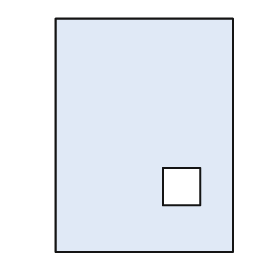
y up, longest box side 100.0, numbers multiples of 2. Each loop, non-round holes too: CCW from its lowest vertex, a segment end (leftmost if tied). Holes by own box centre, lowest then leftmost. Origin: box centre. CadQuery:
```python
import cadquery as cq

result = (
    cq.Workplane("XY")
    .moveTo(-38.0, -50.0)
    .lineTo(38.0, -50.0)
    .lineTo(38.0, 50.0)
    .lineTo(-38.0, 50.0)
    .close()
    .moveTo(8.0, -30.0)
    .lineTo(24.0, -30.0)
    .lineTo(24.0, -14.0)
    .lineTo(8.0, -14.0)
    .close()
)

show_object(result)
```